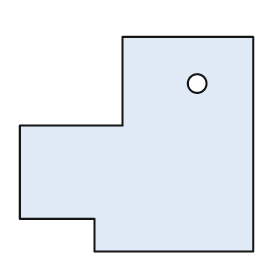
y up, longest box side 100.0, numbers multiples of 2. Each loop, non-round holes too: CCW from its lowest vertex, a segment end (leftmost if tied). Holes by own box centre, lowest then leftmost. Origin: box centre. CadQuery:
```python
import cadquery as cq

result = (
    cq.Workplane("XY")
    .moveTo(-18.0, -46.0)
    .lineTo(50.0, -46.0)
    .lineTo(50.0, 46.0)
    .lineTo(-6.0, 46.0)
    .lineTo(-6.0, 8.0)
    .lineTo(-50.0, 8.0)
    .lineTo(-50.0, -32.0)
    .lineTo(-18.0, -32.0)
    .close()
    .moveTo(26.0, 26.0)
    .circle(4.0)
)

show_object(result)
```